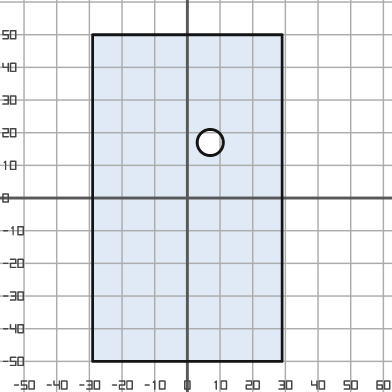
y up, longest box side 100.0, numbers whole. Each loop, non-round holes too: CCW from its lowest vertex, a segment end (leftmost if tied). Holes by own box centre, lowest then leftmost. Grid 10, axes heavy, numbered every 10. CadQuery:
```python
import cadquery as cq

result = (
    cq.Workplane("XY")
    .moveTo(-29.0, -50.0)
    .lineTo(29.0, -50.0)
    .lineTo(29.0, 50.0)
    .lineTo(-29.0, 50.0)
    .close()
    .moveTo(7.0, 17.0)
    .circle(4.0)
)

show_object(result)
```